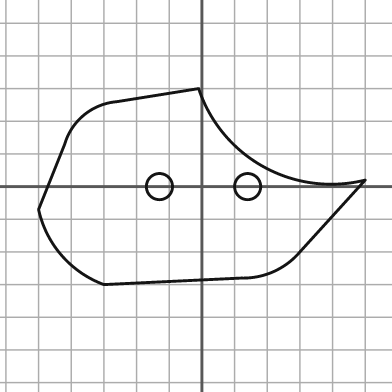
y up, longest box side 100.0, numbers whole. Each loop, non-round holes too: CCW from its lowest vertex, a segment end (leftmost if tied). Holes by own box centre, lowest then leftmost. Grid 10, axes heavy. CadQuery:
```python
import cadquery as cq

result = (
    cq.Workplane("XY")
    .moveTo(-30.0, -30.0)
    .lineTo(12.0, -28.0)
    .threePointArc((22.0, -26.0), (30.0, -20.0))
    .lineTo(50.0, 2.0)
    .threePointArc((19.0, 6.0), (-1.0, 30.0))
    .lineTo(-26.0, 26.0)
    .threePointArc((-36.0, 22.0), (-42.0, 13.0))
    .lineTo(-50.0, -7.0)
    .threePointArc((-43.0, -21.0), (-30.0, -30.0))
    .close()
    .moveTo(-13.0, 0.0)
    .circle(4.0)
    .moveTo(14.0, 0.0)
    .circle(4.0)
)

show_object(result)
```